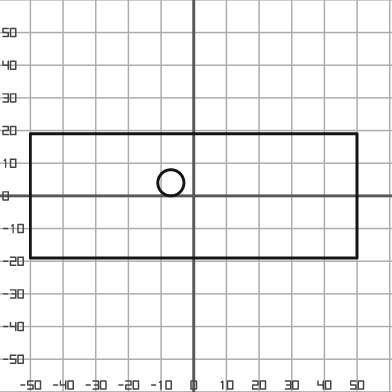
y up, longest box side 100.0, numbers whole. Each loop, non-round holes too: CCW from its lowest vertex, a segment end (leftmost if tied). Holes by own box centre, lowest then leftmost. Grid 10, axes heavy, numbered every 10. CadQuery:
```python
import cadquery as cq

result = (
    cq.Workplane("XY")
    .moveTo(-50.0, -19.0)
    .lineTo(50.0, -19.0)
    .lineTo(50.0, 19.0)
    .lineTo(-50.0, 19.0)
    .close()
    .moveTo(-7.0, 4.0)
    .circle(4.0)
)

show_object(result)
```